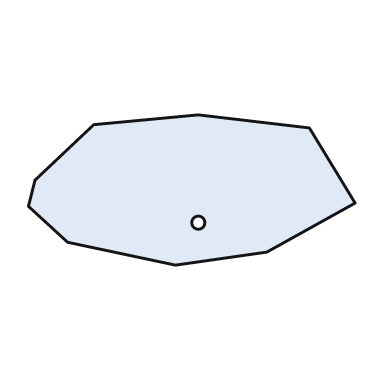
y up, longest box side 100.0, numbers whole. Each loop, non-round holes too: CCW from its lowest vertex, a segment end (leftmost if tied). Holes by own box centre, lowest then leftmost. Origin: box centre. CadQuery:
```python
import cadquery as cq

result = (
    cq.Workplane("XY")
    .moveTo(-5.0, -23.0)
    .lineTo(23.0, -19.0)
    .lineTo(50.0, -4.0)
    .lineTo(36.0, 19.0)
    .lineTo(2.0, 23.0)
    .lineTo(-30.0, 20.0)
    .lineTo(-48.0, 3.0)
    .lineTo(-50.0, -5.0)
    .lineTo(-38.0, -16.0)
    .close()
    .moveTo(2.0, -10.0)
    .circle(2.0)
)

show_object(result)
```